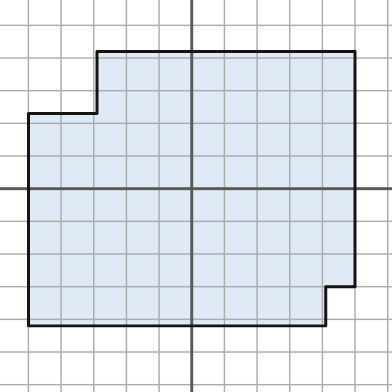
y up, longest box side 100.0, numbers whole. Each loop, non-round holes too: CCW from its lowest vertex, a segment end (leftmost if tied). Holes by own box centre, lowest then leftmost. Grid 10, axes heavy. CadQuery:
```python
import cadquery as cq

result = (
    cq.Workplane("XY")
    .moveTo(-50.0, -42.0)
    .lineTo(41.0, -42.0)
    .lineTo(41.0, -30.0)
    .lineTo(50.0, -30.0)
    .lineTo(50.0, 42.0)
    .lineTo(-29.0, 42.0)
    .lineTo(-29.0, 23.0)
    .lineTo(-50.0, 23.0)
    .close()
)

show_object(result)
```